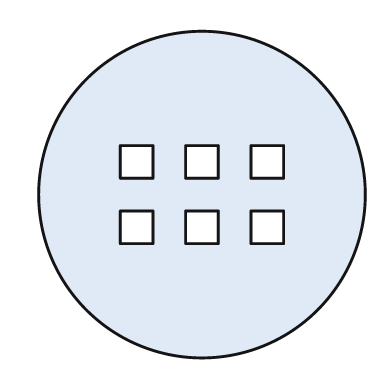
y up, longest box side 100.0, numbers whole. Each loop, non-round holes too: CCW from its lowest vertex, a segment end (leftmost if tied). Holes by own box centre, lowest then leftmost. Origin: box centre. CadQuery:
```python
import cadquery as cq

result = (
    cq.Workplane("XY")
    .moveTo(0.0, 0.0)
    .circle(50.0)
    .moveTo(-25.0, -15.0)
    .lineTo(-15.0, -15.0)
    .lineTo(-15.0, -5.0)
    .lineTo(-25.0, -5.0)
    .close()
    .moveTo(-5.0, -15.0)
    .lineTo(5.0, -15.0)
    .lineTo(5.0, -5.0)
    .lineTo(-5.0, -5.0)
    .close()
    .moveTo(15.0, -15.0)
    .lineTo(25.0, -15.0)
    .lineTo(25.0, -5.0)
    .lineTo(15.0, -5.0)
    .close()
    .moveTo(-25.0, 5.0)
    .lineTo(-15.0, 5.0)
    .lineTo(-15.0, 15.0)
    .lineTo(-25.0, 15.0)
    .close()
    .moveTo(-5.0, 5.0)
    .lineTo(5.0, 5.0)
    .lineTo(5.0, 15.0)
    .lineTo(-5.0, 15.0)
    .close()
    .moveTo(15.0, 5.0)
    .lineTo(25.0, 5.0)
    .lineTo(25.0, 15.0)
    .lineTo(15.0, 15.0)
    .close()
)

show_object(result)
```